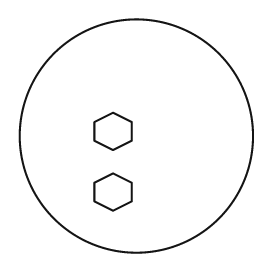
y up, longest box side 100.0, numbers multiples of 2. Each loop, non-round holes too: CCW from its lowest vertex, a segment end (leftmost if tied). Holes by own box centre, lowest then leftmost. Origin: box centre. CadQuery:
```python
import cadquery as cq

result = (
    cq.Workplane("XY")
    .moveTo(0.0, 0.0)
    .circle(50.0)
    .moveTo(-10.0, -32.0)
    .lineTo(-2.0, -28.0)
    .lineTo(-2.0, -20.0)
    .lineTo(-10.0, -16.0)
    .lineTo(-18.0, -20.0)
    .lineTo(-18.0, -28.0)
    .close()
    .moveTo(-10.0, -6.0)
    .lineTo(-2.0, -2.0)
    .lineTo(-2.0, 6.0)
    .lineTo(-10.0, 10.0)
    .lineTo(-18.0, 6.0)
    .lineTo(-18.0, -2.0)
    .close()
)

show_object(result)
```